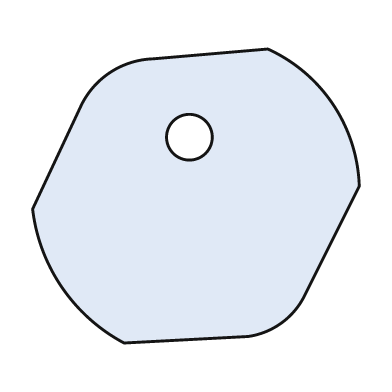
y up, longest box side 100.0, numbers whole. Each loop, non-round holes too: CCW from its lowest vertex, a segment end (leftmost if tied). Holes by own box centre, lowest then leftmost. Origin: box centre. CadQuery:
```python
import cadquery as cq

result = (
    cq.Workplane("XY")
    .moveTo(-22.0, -45.0)
    .lineTo(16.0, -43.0)
    .threePointArc((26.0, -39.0), (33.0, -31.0))
    .lineTo(50.0, 3.0)
    .threePointArc((42.0, 28.0), (22.0, 45.0))
    .lineTo(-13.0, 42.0)
    .threePointArc((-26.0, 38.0), (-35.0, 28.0))
    .lineTo(-50.0, -4.0)
    .threePointArc((-41.0, -28.0), (-22.0, -45.0))
    .close()
    .moveTo(-2.0, 18.0)
    .circle(7.0)
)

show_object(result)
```